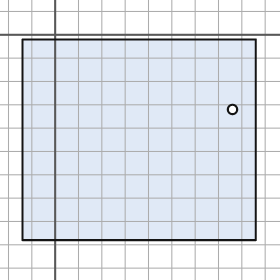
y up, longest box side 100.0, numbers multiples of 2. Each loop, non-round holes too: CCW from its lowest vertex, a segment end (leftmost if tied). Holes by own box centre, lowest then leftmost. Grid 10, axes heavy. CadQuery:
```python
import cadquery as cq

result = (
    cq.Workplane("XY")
    .moveTo(-14.0, -88.0)
    .lineTo(86.0, -88.0)
    .lineTo(86.0, -2.0)
    .lineTo(-14.0, -2.0)
    .close()
    .moveTo(76.0, -32.0)
    .circle(2.0)
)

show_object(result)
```